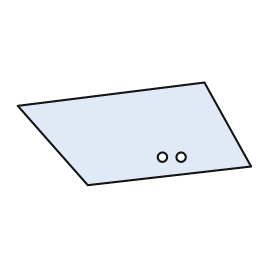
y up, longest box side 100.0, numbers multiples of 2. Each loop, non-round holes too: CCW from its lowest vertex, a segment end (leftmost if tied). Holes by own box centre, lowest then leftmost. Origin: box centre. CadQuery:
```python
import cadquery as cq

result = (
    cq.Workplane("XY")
    .moveTo(-20.0, -22.0)
    .lineTo(50.0, -14.0)
    .lineTo(30.0, 22.0)
    .lineTo(-50.0, 12.0)
    .close()
    .moveTo(12.0, -10.0)
    .circle(2.0)
    .moveTo(20.0, -10.0)
    .circle(2.0)
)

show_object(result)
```